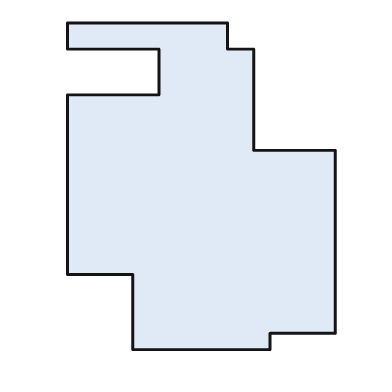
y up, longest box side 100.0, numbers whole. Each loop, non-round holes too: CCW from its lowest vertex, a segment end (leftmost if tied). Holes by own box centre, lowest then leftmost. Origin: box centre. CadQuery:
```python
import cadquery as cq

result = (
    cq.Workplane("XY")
    .moveTo(-21.0, -50.0)
    .lineTo(21.0, -50.0)
    .lineTo(21.0, -45.0)
    .lineTo(41.0, -45.0)
    .lineTo(41.0, 11.0)
    .lineTo(16.0, 11.0)
    .lineTo(16.0, 42.0)
    .lineTo(8.0, 42.0)
    .lineTo(8.0, 50.0)
    .lineTo(-41.0, 50.0)
    .lineTo(-41.0, 42.0)
    .lineTo(-13.0, 42.0)
    .lineTo(-13.0, 28.0)
    .lineTo(-41.0, 28.0)
    .lineTo(-41.0, -27.0)
    .lineTo(-21.0, -27.0)
    .close()
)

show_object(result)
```